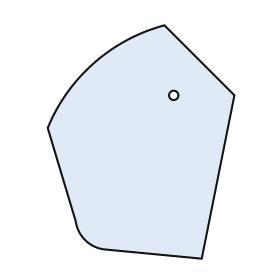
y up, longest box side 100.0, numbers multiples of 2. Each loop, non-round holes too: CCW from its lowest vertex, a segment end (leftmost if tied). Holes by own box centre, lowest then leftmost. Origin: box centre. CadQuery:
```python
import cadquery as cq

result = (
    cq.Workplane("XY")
    .moveTo(26.0, -50.0)
    .lineTo(40.0, 20.0)
    .lineTo(10.0, 50.0)
    .threePointArc((-20.0, 34.0), (-40.0, 6.0))
    .lineTo(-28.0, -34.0)
    .threePointArc((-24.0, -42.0), (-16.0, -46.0))
    .close()
    .moveTo(14.0, 20.0)
    .circle(2.0)
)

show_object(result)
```